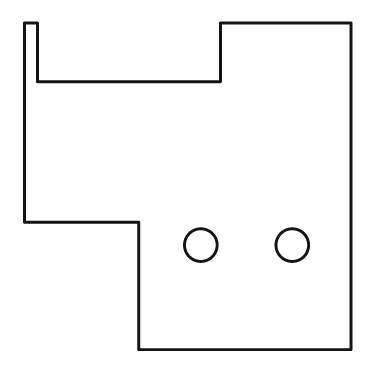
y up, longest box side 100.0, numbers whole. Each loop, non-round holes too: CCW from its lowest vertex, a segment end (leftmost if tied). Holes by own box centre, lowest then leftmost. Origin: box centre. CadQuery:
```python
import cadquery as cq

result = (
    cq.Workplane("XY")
    .moveTo(-15.0, -50.0)
    .lineTo(50.0, -50.0)
    .lineTo(50.0, 50.0)
    .lineTo(10.0, 50.0)
    .lineTo(10.0, 32.0)
    .lineTo(-46.0, 32.0)
    .lineTo(-46.0, 50.0)
    .lineTo(-50.0, 50.0)
    .lineTo(-50.0, -11.0)
    .lineTo(-15.0, -11.0)
    .close()
    .moveTo(4.0, -18.0)
    .circle(5.0)
    .moveTo(32.0, -18.0)
    .circle(5.0)
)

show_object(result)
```